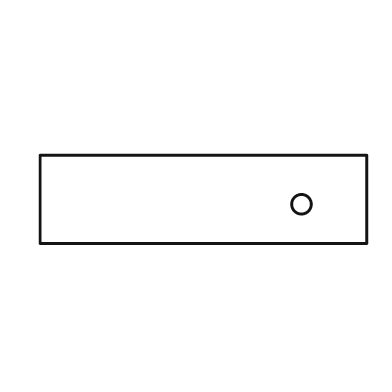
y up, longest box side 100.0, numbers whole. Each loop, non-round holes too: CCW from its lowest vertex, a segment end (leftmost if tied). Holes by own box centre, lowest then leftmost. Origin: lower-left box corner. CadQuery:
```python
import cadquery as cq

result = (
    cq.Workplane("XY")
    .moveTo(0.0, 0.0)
    .lineTo(100.0, 0.0)
    .lineTo(100.0, 27.0)
    .lineTo(0.0, 27.0)
    .close()
    .moveTo(80.0, 12.0)
    .circle(3.0)
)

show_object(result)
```